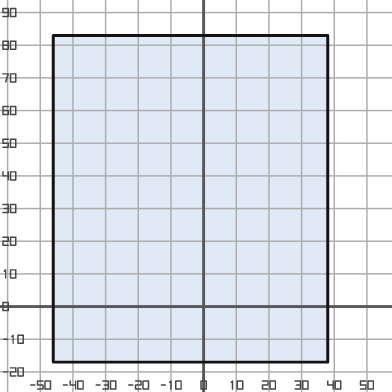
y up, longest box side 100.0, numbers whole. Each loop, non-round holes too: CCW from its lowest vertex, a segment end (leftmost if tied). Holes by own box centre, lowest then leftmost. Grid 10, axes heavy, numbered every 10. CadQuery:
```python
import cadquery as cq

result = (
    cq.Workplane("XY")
    .moveTo(-46.0, -17.0)
    .lineTo(38.0, -17.0)
    .lineTo(38.0, 83.0)
    .lineTo(-46.0, 83.0)
    .close()
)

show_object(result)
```